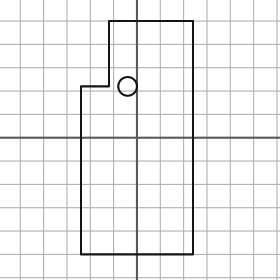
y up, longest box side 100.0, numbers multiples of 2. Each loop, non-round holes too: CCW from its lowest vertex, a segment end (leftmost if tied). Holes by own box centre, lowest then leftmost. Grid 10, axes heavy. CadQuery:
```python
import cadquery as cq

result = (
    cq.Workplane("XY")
    .moveTo(-24.0, -50.0)
    .lineTo(24.0, -50.0)
    .lineTo(24.0, 50.0)
    .lineTo(-12.0, 50.0)
    .lineTo(-12.0, 22.0)
    .lineTo(-24.0, 22.0)
    .close()
    .moveTo(-4.0, 22.0)
    .circle(4.0)
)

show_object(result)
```